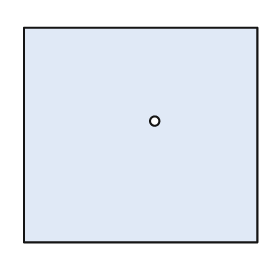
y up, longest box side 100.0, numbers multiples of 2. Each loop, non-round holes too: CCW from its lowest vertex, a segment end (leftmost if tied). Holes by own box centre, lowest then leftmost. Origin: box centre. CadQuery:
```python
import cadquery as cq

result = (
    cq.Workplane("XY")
    .moveTo(-50.0, -46.0)
    .lineTo(50.0, -46.0)
    .lineTo(50.0, 46.0)
    .lineTo(-50.0, 46.0)
    .close()
    .moveTo(6.0, 6.0)
    .circle(2.0)
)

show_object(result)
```